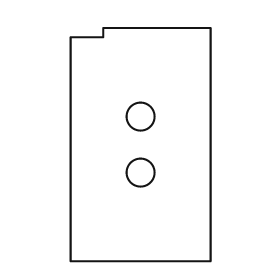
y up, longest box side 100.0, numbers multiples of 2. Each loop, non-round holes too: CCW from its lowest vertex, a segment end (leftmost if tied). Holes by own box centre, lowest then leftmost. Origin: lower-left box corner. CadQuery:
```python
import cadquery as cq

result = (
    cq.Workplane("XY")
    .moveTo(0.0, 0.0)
    .lineTo(60.0, 0.0)
    .lineTo(60.0, 100.0)
    .lineTo(14.0, 100.0)
    .lineTo(14.0, 96.0)
    .lineTo(0.0, 96.0)
    .close()
    .moveTo(30.0, 38.0)
    .circle(6.0)
    .moveTo(30.0, 62.0)
    .circle(6.0)
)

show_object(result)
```